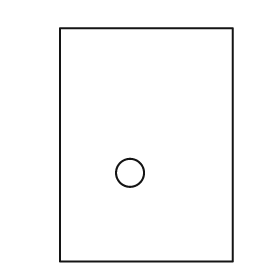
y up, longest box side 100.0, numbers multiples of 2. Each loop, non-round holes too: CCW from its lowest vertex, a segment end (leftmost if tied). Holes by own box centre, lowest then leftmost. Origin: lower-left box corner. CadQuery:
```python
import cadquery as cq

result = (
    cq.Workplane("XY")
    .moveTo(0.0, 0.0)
    .lineTo(74.0, 0.0)
    .lineTo(74.0, 100.0)
    .lineTo(0.0, 100.0)
    .close()
    .moveTo(30.0, 38.0)
    .circle(6.0)
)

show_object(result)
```